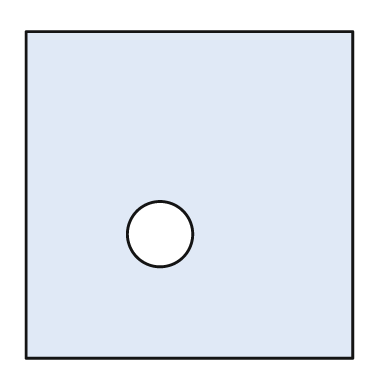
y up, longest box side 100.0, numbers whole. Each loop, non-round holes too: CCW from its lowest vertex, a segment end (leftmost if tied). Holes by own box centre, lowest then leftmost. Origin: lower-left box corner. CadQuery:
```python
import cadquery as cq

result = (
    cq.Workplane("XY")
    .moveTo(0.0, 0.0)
    .lineTo(100.0, 0.0)
    .lineTo(100.0, 100.0)
    .lineTo(0.0, 100.0)
    .close()
    .moveTo(41.0, 38.0)
    .circle(10.0)
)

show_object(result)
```